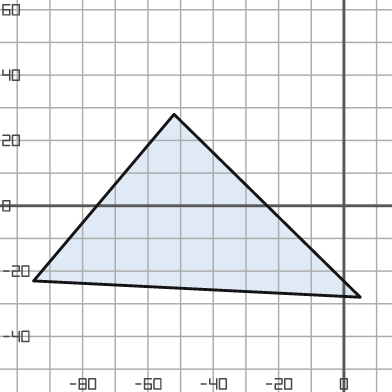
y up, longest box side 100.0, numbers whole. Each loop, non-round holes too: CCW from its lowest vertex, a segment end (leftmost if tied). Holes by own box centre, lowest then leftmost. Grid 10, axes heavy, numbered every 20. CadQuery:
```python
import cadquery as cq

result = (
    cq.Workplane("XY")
    .moveTo(5.0, -28.0)
    .lineTo(-52.0, 28.0)
    .lineTo(-95.0, -23.0)
    .close()
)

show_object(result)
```